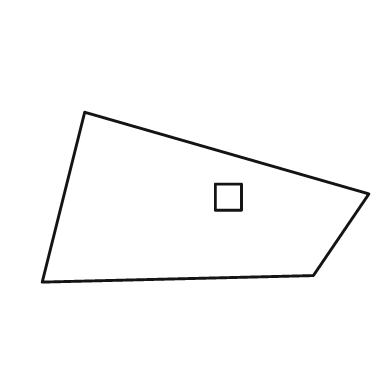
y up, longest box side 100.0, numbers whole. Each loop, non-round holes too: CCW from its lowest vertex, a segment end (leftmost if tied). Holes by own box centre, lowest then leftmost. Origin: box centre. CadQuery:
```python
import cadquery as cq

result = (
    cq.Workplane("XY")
    .moveTo(-50.0, -26.0)
    .lineTo(33.0, -24.0)
    .lineTo(50.0, 1.0)
    .lineTo(-37.0, 26.0)
    .close()
    .moveTo(3.0, -4.0)
    .lineTo(11.0, -4.0)
    .lineTo(11.0, 4.0)
    .lineTo(3.0, 4.0)
    .close()
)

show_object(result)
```